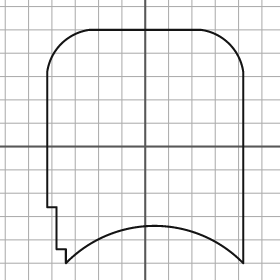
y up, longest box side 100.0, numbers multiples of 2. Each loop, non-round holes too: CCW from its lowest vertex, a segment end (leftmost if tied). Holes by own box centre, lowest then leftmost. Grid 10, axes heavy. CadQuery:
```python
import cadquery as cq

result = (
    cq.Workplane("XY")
    .moveTo(-34.0, -50.0)
    .threePointArc((4.0, -34.0), (42.0, -50.0))
    .lineTo(42.0, 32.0)
    .threePointArc((36.0, 44.0), (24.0, 50.0))
    .lineTo(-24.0, 50.0)
    .threePointArc((-36.0, 44.0), (-42.0, 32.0))
    .lineTo(-42.0, -26.0)
    .lineTo(-38.0, -26.0)
    .lineTo(-38.0, -44.0)
    .lineTo(-34.0, -44.0)
    .close()
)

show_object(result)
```